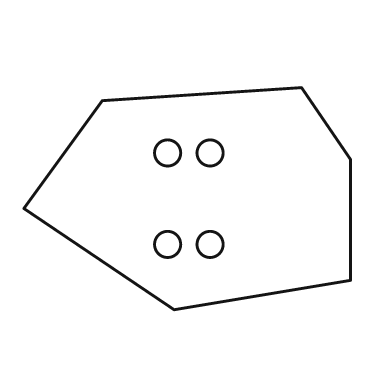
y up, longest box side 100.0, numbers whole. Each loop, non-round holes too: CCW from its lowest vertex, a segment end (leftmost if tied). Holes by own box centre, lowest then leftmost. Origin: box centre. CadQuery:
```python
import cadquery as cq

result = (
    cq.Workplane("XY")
    .moveTo(-4.0, -34.0)
    .lineTo(50.0, -25.0)
    .lineTo(50.0, 12.0)
    .lineTo(35.0, 34.0)
    .lineTo(-26.0, 30.0)
    .lineTo(-50.0, -3.0)
    .close()
    .moveTo(-6.0, -14.0)
    .circle(4.0)
    .moveTo(7.0, -14.0)
    .circle(4.0)
    .moveTo(-6.0, 14.0)
    .circle(4.0)
    .moveTo(7.0, 14.0)
    .circle(4.0)
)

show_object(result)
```